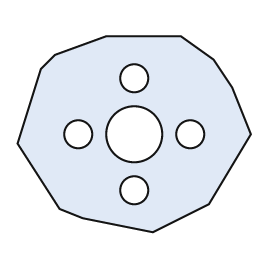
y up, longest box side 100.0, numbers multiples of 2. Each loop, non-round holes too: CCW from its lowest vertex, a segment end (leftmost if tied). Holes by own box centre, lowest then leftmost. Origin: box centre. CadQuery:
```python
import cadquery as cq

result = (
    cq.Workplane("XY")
    .moveTo(8.0, -42.0)
    .lineTo(32.0, -30.0)
    .lineTo(50.0, 0.0)
    .lineTo(42.0, 20.0)
    .lineTo(34.0, 32.0)
    .lineTo(20.0, 42.0)
    .lineTo(-12.0, 42.0)
    .lineTo(-34.0, 34.0)
    .lineTo(-40.0, 28.0)
    .lineTo(-50.0, -4.0)
    .lineTo(-32.0, -32.0)
    .lineTo(-22.0, -36.0)
    .close()
    .moveTo(0.0, -24.0)
    .circle(6.0)
    .moveTo(-24.0, 0.0)
    .circle(6.0)
    .moveTo(0.0, 0.0)
    .circle(12.0)
    .moveTo(24.0, 0.0)
    .circle(6.0)
    .moveTo(0.0, 24.0)
    .circle(6.0)
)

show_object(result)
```